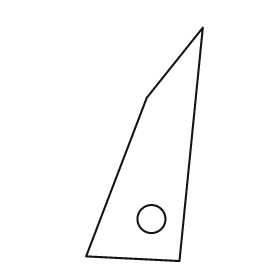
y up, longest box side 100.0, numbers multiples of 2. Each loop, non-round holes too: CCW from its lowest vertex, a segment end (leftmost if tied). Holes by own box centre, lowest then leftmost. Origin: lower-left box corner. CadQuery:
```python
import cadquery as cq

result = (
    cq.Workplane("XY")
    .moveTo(40.0, 0.0)
    .lineTo(50.0, 100.0)
    .lineTo(26.0, 70.0)
    .lineTo(0.0, 2.0)
    .close()
    .moveTo(28.0, 18.0)
    .circle(6.0)
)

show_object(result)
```